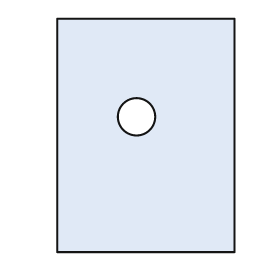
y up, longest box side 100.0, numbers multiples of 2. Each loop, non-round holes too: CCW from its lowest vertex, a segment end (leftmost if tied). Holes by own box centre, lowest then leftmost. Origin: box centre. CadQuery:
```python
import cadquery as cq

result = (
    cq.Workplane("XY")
    .moveTo(-38.0, -50.0)
    .lineTo(38.0, -50.0)
    .lineTo(38.0, 50.0)
    .lineTo(-38.0, 50.0)
    .close()
    .moveTo(-4.0, 8.0)
    .circle(8.0)
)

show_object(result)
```